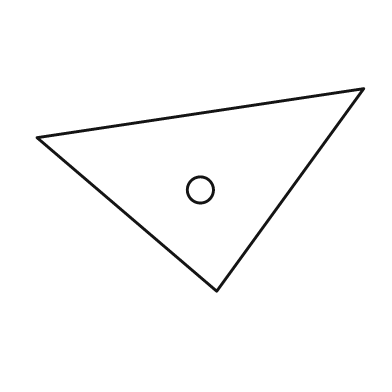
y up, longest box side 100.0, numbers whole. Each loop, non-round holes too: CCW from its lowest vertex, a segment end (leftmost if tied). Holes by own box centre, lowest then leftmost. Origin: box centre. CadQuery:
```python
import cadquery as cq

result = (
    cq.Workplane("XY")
    .moveTo(5.0, -31.0)
    .lineTo(50.0, 31.0)
    .lineTo(-50.0, 16.0)
    .close()
    .moveTo(0.0, 0.0)
    .circle(4.0)
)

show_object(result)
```